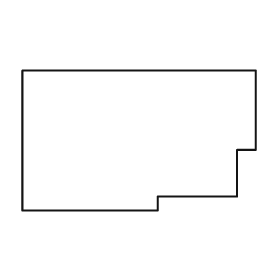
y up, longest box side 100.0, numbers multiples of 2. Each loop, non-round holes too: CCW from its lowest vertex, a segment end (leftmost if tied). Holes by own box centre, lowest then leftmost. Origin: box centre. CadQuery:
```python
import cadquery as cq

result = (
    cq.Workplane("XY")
    .moveTo(-50.0, -30.0)
    .lineTo(8.0, -30.0)
    .lineTo(8.0, -24.0)
    .lineTo(42.0, -24.0)
    .lineTo(42.0, -4.0)
    .lineTo(50.0, -4.0)
    .lineTo(50.0, 30.0)
    .lineTo(-50.0, 30.0)
    .close()
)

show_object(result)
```